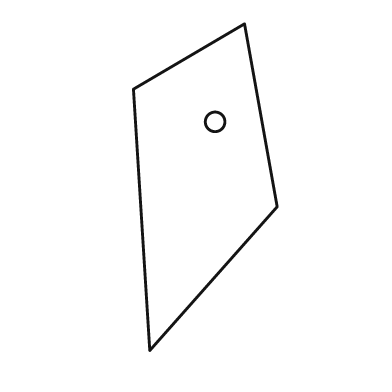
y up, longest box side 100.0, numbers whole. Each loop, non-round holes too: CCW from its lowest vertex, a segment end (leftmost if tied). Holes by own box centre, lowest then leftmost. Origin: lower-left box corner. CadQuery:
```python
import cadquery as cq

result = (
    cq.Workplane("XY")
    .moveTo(5.0, 0.0)
    .lineTo(44.0, 44.0)
    .lineTo(34.0, 100.0)
    .lineTo(0.0, 80.0)
    .close()
    .moveTo(25.0, 70.0)
    .circle(3.0)
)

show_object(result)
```